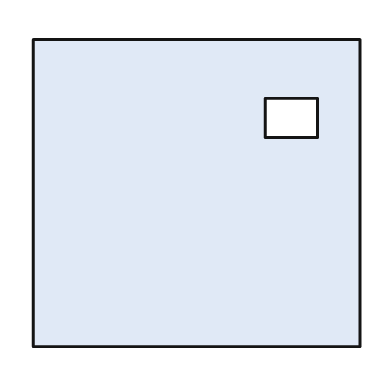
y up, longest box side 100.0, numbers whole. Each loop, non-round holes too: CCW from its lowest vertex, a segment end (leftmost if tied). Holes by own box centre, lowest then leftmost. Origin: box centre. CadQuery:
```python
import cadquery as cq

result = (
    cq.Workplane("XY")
    .moveTo(-50.0, -47.0)
    .lineTo(50.0, -47.0)
    .lineTo(50.0, 47.0)
    .lineTo(-50.0, 47.0)
    .close()
    .moveTo(21.0, 17.0)
    .lineTo(37.0, 17.0)
    .lineTo(37.0, 29.0)
    .lineTo(21.0, 29.0)
    .close()
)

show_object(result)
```